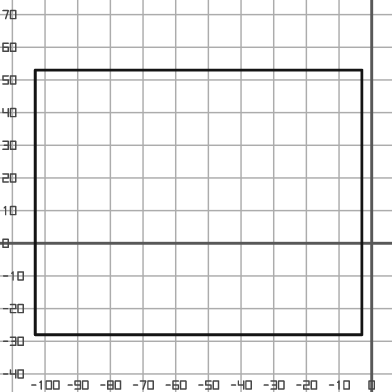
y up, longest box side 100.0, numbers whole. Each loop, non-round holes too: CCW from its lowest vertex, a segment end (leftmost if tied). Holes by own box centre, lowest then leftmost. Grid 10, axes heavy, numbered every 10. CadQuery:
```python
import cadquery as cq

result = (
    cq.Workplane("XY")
    .moveTo(-103.0, -28.0)
    .lineTo(-3.0, -28.0)
    .lineTo(-3.0, 53.0)
    .lineTo(-103.0, 53.0)
    .close()
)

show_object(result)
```